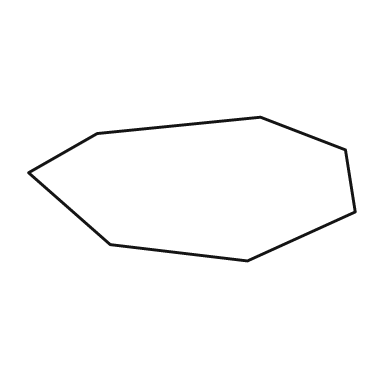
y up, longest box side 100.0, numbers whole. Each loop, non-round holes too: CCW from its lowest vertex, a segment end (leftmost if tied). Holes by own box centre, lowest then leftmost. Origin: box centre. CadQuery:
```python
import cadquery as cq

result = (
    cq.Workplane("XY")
    .moveTo(17.0, -22.0)
    .lineTo(50.0, -7.0)
    .lineTo(47.0, 12.0)
    .lineTo(21.0, 22.0)
    .lineTo(-29.0, 17.0)
    .lineTo(-50.0, 5.0)
    .lineTo(-25.0, -17.0)
    .close()
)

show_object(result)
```